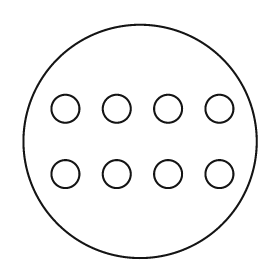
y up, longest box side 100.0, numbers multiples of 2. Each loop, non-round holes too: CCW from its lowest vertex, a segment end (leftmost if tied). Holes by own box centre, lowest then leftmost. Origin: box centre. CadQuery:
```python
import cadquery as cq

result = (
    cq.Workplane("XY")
    .moveTo(0.0, 0.0)
    .circle(50.0)
    .moveTo(-32.0, -14.0)
    .circle(6.0)
    .moveTo(-10.0, -14.0)
    .circle(6.0)
    .moveTo(12.0, -14.0)
    .circle(6.0)
    .moveTo(34.0, -14.0)
    .circle(6.0)
    .moveTo(-32.0, 14.0)
    .circle(6.0)
    .moveTo(-10.0, 14.0)
    .circle(6.0)
    .moveTo(12.0, 14.0)
    .circle(6.0)
    .moveTo(34.0, 14.0)
    .circle(6.0)
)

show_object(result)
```